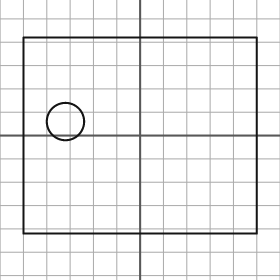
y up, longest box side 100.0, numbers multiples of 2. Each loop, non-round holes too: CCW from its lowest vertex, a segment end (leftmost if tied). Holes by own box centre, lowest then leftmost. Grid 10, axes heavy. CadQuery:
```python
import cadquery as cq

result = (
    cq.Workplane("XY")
    .moveTo(-50.0, -42.0)
    .lineTo(50.0, -42.0)
    .lineTo(50.0, 42.0)
    .lineTo(-50.0, 42.0)
    .close()
    .moveTo(-32.0, 6.0)
    .circle(8.0)
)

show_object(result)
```